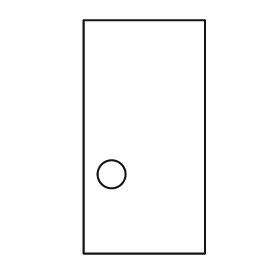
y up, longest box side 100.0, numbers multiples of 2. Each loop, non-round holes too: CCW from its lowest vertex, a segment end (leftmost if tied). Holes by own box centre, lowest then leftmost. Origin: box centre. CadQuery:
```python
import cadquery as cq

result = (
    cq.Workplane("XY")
    .moveTo(-26.0, -50.0)
    .lineTo(26.0, -50.0)
    .lineTo(26.0, 50.0)
    .lineTo(-26.0, 50.0)
    .close()
    .moveTo(-14.0, -16.0)
    .circle(6.0)
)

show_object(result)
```